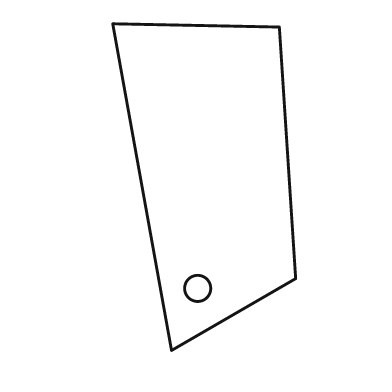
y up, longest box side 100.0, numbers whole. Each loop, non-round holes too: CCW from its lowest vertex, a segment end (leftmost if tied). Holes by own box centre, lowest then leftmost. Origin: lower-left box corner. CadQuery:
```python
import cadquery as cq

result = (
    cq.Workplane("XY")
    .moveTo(18.0, 0.0)
    .lineTo(56.0, 22.0)
    .lineTo(51.0, 99.0)
    .lineTo(0.0, 100.0)
    .close()
    .moveTo(26.0, 19.0)
    .circle(4.0)
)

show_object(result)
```